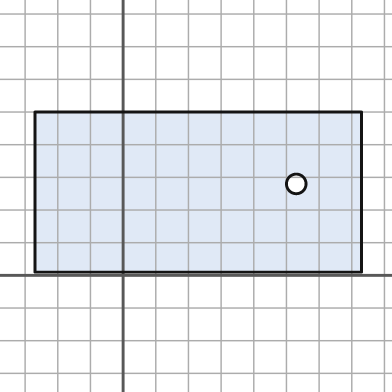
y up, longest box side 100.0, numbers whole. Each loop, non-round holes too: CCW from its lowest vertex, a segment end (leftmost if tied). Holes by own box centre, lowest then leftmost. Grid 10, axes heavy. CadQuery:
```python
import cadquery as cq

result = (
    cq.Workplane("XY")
    .moveTo(-27.0, 1.0)
    .lineTo(73.0, 1.0)
    .lineTo(73.0, 50.0)
    .lineTo(-27.0, 50.0)
    .close()
    .moveTo(53.0, 28.0)
    .circle(3.0)
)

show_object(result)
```